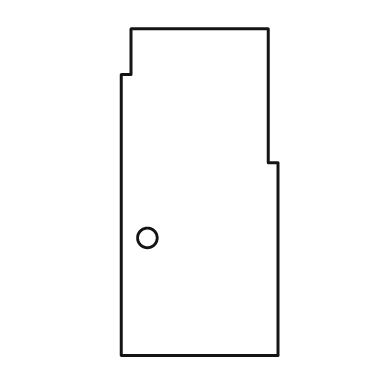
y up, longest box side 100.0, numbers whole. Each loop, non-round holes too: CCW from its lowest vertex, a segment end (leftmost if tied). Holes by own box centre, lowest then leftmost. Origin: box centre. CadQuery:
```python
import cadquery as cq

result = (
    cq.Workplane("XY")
    .moveTo(-24.0, -50.0)
    .lineTo(24.0, -50.0)
    .lineTo(24.0, 9.0)
    .lineTo(21.0, 9.0)
    .lineTo(21.0, 50.0)
    .lineTo(-21.0, 50.0)
    .lineTo(-21.0, 36.0)
    .lineTo(-24.0, 36.0)
    .close()
    .moveTo(-16.0, -14.0)
    .circle(3.0)
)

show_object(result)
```